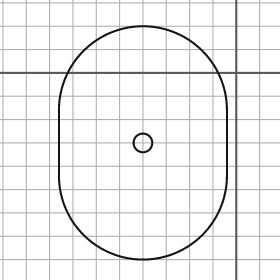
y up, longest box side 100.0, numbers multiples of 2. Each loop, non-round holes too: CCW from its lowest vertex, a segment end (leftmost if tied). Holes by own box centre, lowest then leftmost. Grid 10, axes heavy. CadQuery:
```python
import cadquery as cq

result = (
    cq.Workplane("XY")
    .moveTo(-76.0, -44.0)
    .threePointArc((-40.0, -80.0), (-4.0, -44.0))
    .lineTo(-4.0, -16.0)
    .threePointArc((-40.0, 20.0), (-76.0, -16.0))
    .close()
    .moveTo(-40.0, -30.0)
    .circle(4.0)
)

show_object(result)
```